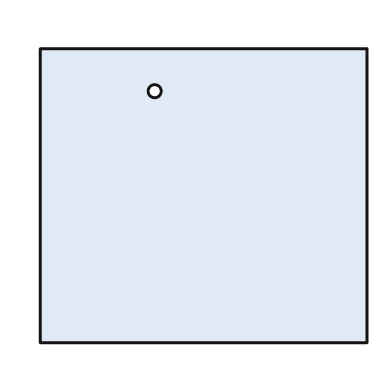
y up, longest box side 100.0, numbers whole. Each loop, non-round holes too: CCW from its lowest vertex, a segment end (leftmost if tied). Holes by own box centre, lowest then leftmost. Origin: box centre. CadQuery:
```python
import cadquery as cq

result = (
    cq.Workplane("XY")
    .moveTo(-50.0, -45.0)
    .lineTo(50.0, -45.0)
    .lineTo(50.0, 45.0)
    .lineTo(-50.0, 45.0)
    .close()
    .moveTo(-15.0, 32.0)
    .circle(2.0)
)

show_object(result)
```